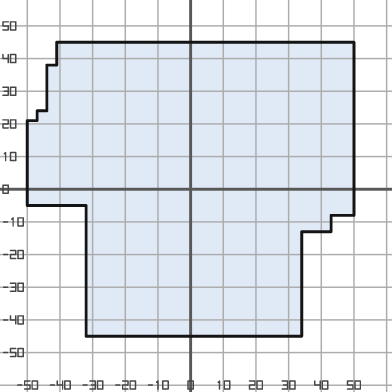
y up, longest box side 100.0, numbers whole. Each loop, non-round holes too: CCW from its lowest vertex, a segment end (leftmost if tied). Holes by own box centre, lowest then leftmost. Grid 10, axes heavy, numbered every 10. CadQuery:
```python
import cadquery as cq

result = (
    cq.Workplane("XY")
    .moveTo(-32.0, -45.0)
    .lineTo(34.0, -45.0)
    .lineTo(34.0, -13.0)
    .lineTo(43.0, -13.0)
    .lineTo(43.0, -8.0)
    .lineTo(50.0, -8.0)
    .lineTo(50.0, 45.0)
    .lineTo(-41.0, 45.0)
    .lineTo(-41.0, 38.0)
    .lineTo(-44.0, 38.0)
    .lineTo(-44.0, 24.0)
    .lineTo(-47.0, 24.0)
    .lineTo(-47.0, 21.0)
    .lineTo(-50.0, 21.0)
    .lineTo(-50.0, -5.0)
    .lineTo(-32.0, -5.0)
    .close()
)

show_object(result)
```